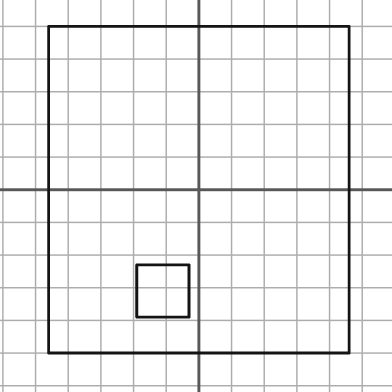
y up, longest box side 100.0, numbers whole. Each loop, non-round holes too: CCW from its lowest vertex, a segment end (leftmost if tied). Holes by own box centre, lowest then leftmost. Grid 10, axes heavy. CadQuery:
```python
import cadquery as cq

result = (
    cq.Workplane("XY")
    .moveTo(-46.0, -50.0)
    .lineTo(46.0, -50.0)
    .lineTo(46.0, 50.0)
    .lineTo(-46.0, 50.0)
    .close()
    .moveTo(-19.0, -39.0)
    .lineTo(-3.0, -39.0)
    .lineTo(-3.0, -23.0)
    .lineTo(-19.0, -23.0)
    .close()
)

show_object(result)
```